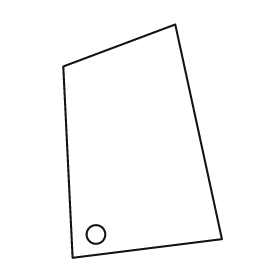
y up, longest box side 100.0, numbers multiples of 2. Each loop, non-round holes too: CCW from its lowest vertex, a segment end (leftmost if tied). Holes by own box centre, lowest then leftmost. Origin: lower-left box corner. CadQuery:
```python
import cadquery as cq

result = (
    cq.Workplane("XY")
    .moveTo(4.0, 0.0)
    .lineTo(68.0, 8.0)
    .lineTo(48.0, 100.0)
    .lineTo(0.0, 82.0)
    .close()
    .moveTo(14.0, 10.0)
    .circle(4.0)
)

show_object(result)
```